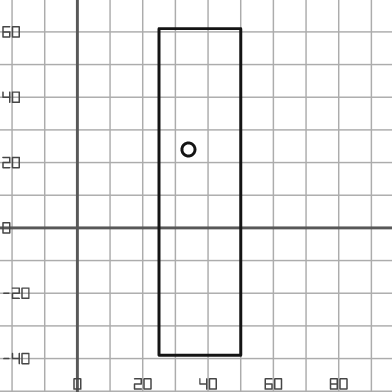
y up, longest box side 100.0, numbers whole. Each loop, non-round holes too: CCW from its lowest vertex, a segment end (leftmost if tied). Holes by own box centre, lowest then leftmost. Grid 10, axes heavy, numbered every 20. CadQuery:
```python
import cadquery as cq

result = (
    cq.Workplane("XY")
    .moveTo(25.0, -39.0)
    .lineTo(50.0, -39.0)
    .lineTo(50.0, 61.0)
    .lineTo(25.0, 61.0)
    .close()
    .moveTo(34.0, 24.0)
    .circle(2.0)
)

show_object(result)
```